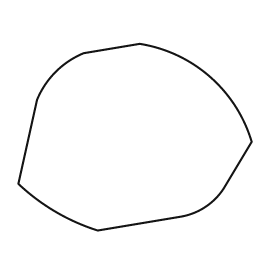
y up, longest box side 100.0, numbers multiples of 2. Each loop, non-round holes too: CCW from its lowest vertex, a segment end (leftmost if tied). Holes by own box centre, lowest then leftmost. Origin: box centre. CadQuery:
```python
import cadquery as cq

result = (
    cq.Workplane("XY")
    .moveTo(-16.0, -40.0)
    .lineTo(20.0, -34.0)
    .threePointArc((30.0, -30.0), (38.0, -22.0))
    .lineTo(50.0, -2.0)
    .threePointArc((32.0, 26.0), (2.0, 40.0))
    .lineTo(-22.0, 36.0)
    .threePointArc((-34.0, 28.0), (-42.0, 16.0))
    .lineTo(-50.0, -20.0)
    .threePointArc((-34.0, -32.0), (-16.0, -40.0))
    .close()
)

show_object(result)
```